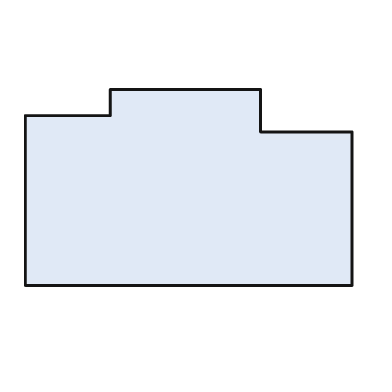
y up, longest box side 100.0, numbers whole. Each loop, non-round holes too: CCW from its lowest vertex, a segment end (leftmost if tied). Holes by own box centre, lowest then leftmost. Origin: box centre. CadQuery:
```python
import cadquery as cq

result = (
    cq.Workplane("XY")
    .moveTo(-50.0, -30.0)
    .lineTo(50.0, -30.0)
    .lineTo(50.0, 17.0)
    .lineTo(22.0, 17.0)
    .lineTo(22.0, 30.0)
    .lineTo(-24.0, 30.0)
    .lineTo(-24.0, 22.0)
    .lineTo(-50.0, 22.0)
    .close()
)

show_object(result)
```